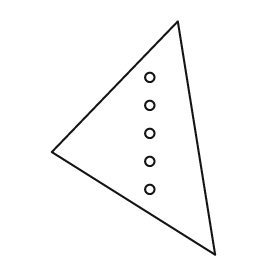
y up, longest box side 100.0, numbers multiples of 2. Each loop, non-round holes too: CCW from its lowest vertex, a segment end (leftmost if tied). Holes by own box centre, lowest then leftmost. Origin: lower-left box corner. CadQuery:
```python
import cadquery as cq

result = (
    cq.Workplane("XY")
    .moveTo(70.0, 0.0)
    .lineTo(54.0, 100.0)
    .lineTo(0.0, 44.0)
    .close()
    .moveTo(42.0, 28.0)
    .circle(2.0)
    .moveTo(42.0, 40.0)
    .circle(2.0)
    .moveTo(42.0, 52.0)
    .circle(2.0)
    .moveTo(42.0, 64.0)
    .circle(2.0)
    .moveTo(42.0, 76.0)
    .circle(2.0)
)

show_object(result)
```